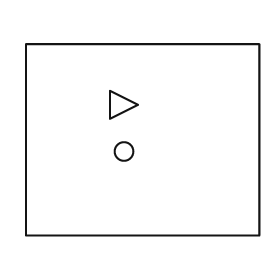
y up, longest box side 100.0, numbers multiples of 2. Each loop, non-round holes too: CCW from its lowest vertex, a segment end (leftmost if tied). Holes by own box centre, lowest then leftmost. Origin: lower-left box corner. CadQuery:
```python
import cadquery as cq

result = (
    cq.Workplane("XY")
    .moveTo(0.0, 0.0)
    .lineTo(100.0, 0.0)
    .lineTo(100.0, 82.0)
    .lineTo(0.0, 82.0)
    .close()
    .moveTo(42.0, 36.0)
    .circle(4.0)
    .moveTo(36.0, 50.0)
    .lineTo(48.0, 56.0)
    .lineTo(36.0, 62.0)
    .close()
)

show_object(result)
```